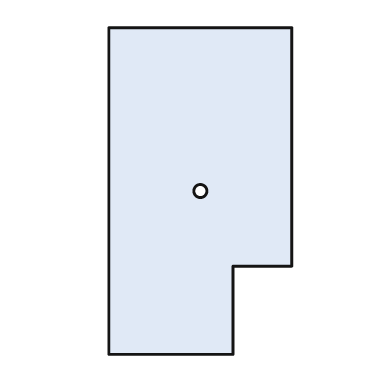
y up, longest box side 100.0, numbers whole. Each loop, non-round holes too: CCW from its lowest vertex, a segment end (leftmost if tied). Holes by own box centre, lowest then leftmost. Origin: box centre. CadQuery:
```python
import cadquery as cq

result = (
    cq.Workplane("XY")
    .moveTo(-28.0, -50.0)
    .lineTo(10.0, -50.0)
    .lineTo(10.0, -23.0)
    .lineTo(28.0, -23.0)
    .lineTo(28.0, 50.0)
    .lineTo(-28.0, 50.0)
    .close()
    .moveTo(0.0, 0.0)
    .circle(2.0)
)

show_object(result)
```